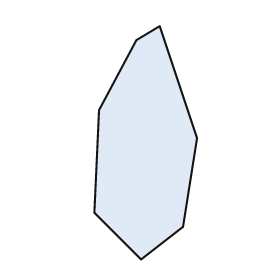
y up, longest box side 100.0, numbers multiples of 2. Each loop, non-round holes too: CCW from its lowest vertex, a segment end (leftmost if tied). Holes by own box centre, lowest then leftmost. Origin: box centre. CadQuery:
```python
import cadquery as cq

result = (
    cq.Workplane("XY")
    .moveTo(-2.0, -50.0)
    .lineTo(16.0, -36.0)
    .lineTo(22.0, 2.0)
    .lineTo(6.0, 50.0)
    .lineTo(-4.0, 44.0)
    .lineTo(-20.0, 14.0)
    .lineTo(-22.0, -30.0)
    .close()
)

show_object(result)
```